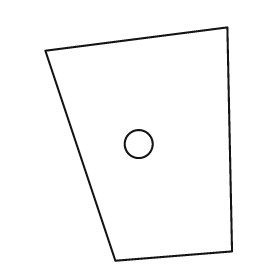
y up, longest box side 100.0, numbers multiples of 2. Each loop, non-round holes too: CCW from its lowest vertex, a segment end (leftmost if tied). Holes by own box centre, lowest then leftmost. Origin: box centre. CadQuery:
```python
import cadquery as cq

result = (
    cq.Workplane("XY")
    .moveTo(-10.0, -50.0)
    .lineTo(40.0, -46.0)
    .lineTo(38.0, 50.0)
    .lineTo(-40.0, 40.0)
    .close()
    .moveTo(0.0, 0.0)
    .circle(6.0)
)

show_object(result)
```